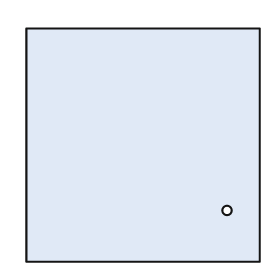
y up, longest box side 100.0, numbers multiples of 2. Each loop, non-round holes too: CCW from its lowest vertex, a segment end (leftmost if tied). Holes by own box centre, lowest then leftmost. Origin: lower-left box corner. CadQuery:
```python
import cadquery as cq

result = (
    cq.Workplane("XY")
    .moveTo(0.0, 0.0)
    .lineTo(100.0, 0.0)
    .lineTo(100.0, 100.0)
    .lineTo(0.0, 100.0)
    .close()
    .moveTo(86.0, 22.0)
    .circle(2.0)
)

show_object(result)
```